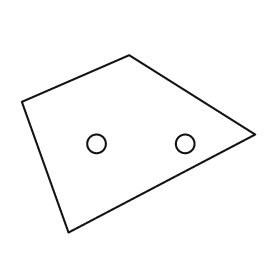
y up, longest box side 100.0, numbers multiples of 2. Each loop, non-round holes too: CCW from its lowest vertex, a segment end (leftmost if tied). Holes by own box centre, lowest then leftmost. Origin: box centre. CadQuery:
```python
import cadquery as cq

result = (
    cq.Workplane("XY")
    .moveTo(-30.0, -38.0)
    .lineTo(50.0, 4.0)
    .lineTo(-4.0, 38.0)
    .lineTo(-50.0, 18.0)
    .close()
    .moveTo(-18.0, 0.0)
    .circle(4.0)
    .moveTo(20.0, 0.0)
    .circle(4.0)
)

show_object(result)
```